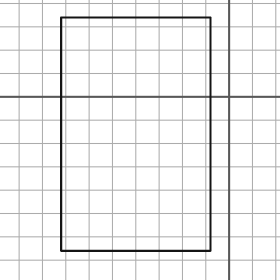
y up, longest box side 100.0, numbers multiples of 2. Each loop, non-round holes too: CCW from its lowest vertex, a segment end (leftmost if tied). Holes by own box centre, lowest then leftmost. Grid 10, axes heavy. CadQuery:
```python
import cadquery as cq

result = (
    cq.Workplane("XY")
    .moveTo(-72.0, -66.0)
    .lineTo(-8.0, -66.0)
    .lineTo(-8.0, 34.0)
    .lineTo(-72.0, 34.0)
    .close()
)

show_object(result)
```